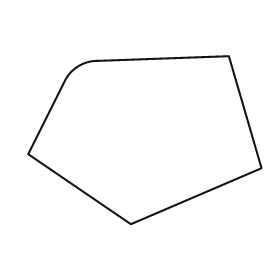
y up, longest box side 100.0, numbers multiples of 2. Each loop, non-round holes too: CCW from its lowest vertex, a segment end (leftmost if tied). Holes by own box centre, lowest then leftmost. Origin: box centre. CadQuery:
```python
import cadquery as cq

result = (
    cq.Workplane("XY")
    .moveTo(-6.0, -36.0)
    .lineTo(50.0, -12.0)
    .lineTo(36.0, 36.0)
    .lineTo(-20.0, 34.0)
    .threePointArc((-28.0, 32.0), (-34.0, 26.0))
    .lineTo(-50.0, -6.0)
    .close()
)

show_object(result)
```